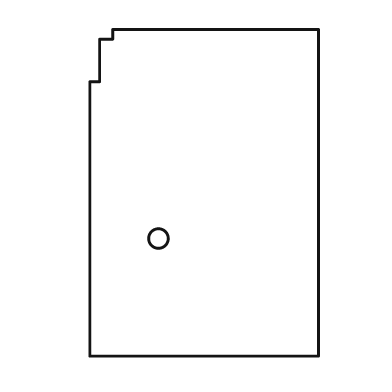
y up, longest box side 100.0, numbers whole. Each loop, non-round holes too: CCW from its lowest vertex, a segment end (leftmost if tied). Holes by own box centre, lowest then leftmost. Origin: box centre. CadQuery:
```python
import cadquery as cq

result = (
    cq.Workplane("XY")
    .moveTo(-35.0, -50.0)
    .lineTo(35.0, -50.0)
    .lineTo(35.0, 50.0)
    .lineTo(-28.0, 50.0)
    .lineTo(-28.0, 47.0)
    .lineTo(-32.0, 47.0)
    .lineTo(-32.0, 34.0)
    .lineTo(-35.0, 34.0)
    .close()
    .moveTo(-14.0, -14.0)
    .circle(3.0)
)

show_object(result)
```